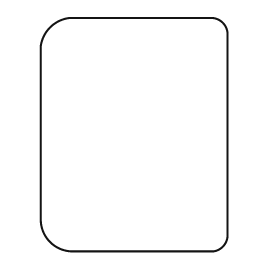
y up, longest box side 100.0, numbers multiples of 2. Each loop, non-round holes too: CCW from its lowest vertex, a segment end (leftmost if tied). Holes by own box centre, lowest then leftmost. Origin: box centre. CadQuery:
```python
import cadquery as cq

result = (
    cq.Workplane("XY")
    .moveTo(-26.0, -50.0)
    .lineTo(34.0, -50.0)
    .threePointArc((38.0, -48.0), (40.0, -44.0))
    .lineTo(40.0, 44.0)
    .threePointArc((38.0, 48.0), (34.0, 50.0))
    .lineTo(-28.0, 50.0)
    .threePointArc((-36.0, 46.0), (-40.0, 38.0))
    .lineTo(-40.0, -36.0)
    .threePointArc((-36.0, -46.0), (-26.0, -50.0))
    .close()
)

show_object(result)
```